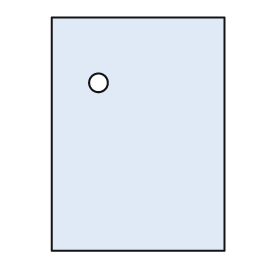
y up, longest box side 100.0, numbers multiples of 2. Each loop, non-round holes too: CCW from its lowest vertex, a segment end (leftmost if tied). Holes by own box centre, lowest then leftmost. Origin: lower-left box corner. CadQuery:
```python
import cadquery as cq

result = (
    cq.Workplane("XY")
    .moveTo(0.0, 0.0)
    .lineTo(74.0, 0.0)
    .lineTo(74.0, 100.0)
    .lineTo(0.0, 100.0)
    .close()
    .moveTo(20.0, 72.0)
    .circle(4.0)
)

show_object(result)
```